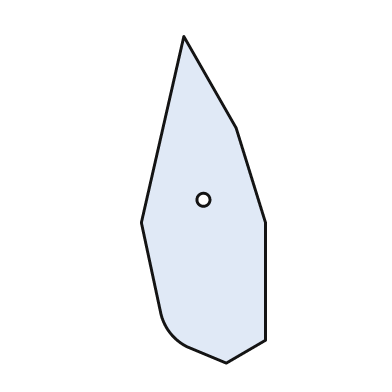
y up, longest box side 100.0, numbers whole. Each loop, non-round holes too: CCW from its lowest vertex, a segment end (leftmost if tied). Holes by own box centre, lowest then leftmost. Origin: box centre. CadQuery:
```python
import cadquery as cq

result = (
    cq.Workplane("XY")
    .moveTo(7.0, -50.0)
    .lineTo(19.0, -43.0)
    .lineTo(19.0, -7.0)
    .lineTo(10.0, 22.0)
    .lineTo(-6.0, 50.0)
    .lineTo(-19.0, -7.0)
    .lineTo(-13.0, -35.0)
    .threePointArc((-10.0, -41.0), (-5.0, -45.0))
    .close()
    .moveTo(0.0, 0.0)
    .circle(2.0)
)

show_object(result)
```